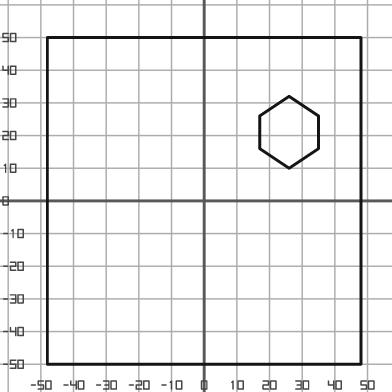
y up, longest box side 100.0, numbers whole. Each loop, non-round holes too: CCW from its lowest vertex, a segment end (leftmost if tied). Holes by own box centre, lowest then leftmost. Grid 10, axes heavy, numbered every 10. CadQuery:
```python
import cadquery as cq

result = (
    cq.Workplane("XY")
    .moveTo(-48.0, -50.0)
    .lineTo(48.0, -50.0)
    .lineTo(48.0, 50.0)
    .lineTo(-48.0, 50.0)
    .close()
    .moveTo(26.0, 10.0)
    .lineTo(35.0, 16.0)
    .lineTo(35.0, 26.0)
    .lineTo(26.0, 32.0)
    .lineTo(17.0, 26.0)
    .lineTo(17.0, 16.0)
    .close()
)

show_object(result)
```